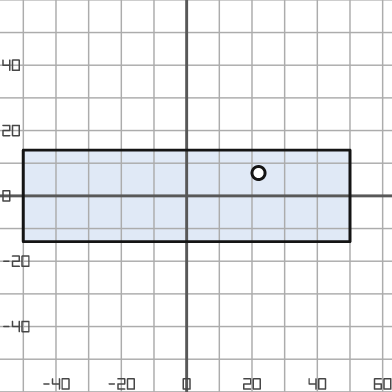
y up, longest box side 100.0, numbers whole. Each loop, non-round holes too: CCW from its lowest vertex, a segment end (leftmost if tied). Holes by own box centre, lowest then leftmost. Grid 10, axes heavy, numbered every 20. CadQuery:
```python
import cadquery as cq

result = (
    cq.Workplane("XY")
    .moveTo(-50.0, -14.0)
    .lineTo(50.0, -14.0)
    .lineTo(50.0, 14.0)
    .lineTo(-50.0, 14.0)
    .close()
    .moveTo(22.0, 7.0)
    .circle(2.0)
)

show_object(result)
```